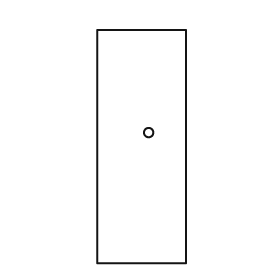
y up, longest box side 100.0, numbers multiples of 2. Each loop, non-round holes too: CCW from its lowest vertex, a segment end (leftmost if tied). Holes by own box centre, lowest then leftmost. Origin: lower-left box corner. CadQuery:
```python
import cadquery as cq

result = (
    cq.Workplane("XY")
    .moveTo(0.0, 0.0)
    .lineTo(38.0, 0.0)
    .lineTo(38.0, 100.0)
    .lineTo(0.0, 100.0)
    .close()
    .moveTo(22.0, 56.0)
    .circle(2.0)
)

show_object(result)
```